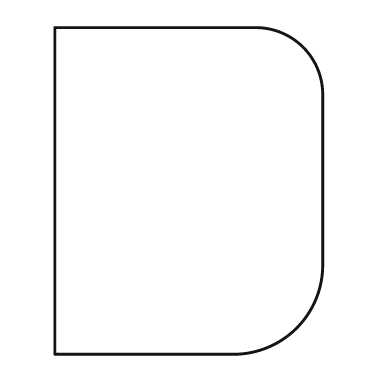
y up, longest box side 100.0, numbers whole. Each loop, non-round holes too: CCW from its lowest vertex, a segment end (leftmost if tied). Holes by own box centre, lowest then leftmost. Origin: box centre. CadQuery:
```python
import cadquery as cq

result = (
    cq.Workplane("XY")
    .moveTo(-41.0, -50.0)
    .lineTo(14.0, -50.0)
    .threePointArc((33.0, -42.0), (41.0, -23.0))
    .lineTo(41.0, 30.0)
    .threePointArc((35.0, 44.0), (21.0, 50.0))
    .lineTo(-41.0, 50.0)
    .close()
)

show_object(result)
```